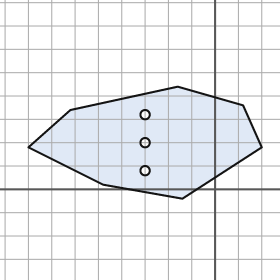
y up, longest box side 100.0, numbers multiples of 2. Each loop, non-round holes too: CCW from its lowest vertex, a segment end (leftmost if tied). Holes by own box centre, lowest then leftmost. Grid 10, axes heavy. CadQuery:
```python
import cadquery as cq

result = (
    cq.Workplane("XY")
    .moveTo(-14.0, -4.0)
    .lineTo(20.0, 18.0)
    .lineTo(12.0, 36.0)
    .lineTo(-16.0, 44.0)
    .lineTo(-62.0, 34.0)
    .lineTo(-80.0, 18.0)
    .lineTo(-48.0, 2.0)
    .close()
    .moveTo(-30.0, 8.0)
    .circle(2.0)
    .moveTo(-30.0, 20.0)
    .circle(2.0)
    .moveTo(-30.0, 32.0)
    .circle(2.0)
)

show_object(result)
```